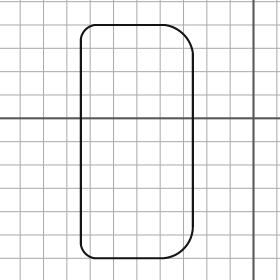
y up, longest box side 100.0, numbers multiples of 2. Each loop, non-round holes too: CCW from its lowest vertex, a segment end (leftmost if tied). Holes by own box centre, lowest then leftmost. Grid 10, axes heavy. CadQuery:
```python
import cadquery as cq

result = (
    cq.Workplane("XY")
    .moveTo(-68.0, -60.0)
    .lineTo(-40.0, -60.0)
    .threePointArc((-30.0, -56.0), (-26.0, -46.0))
    .lineTo(-26.0, 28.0)
    .threePointArc((-30.0, 36.0), (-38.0, 40.0))
    .lineTo(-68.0, 40.0)
    .threePointArc((-72.0, 38.0), (-74.0, 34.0))
    .lineTo(-74.0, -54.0)
    .threePointArc((-72.0, -58.0), (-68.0, -60.0))
    .close()
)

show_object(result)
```